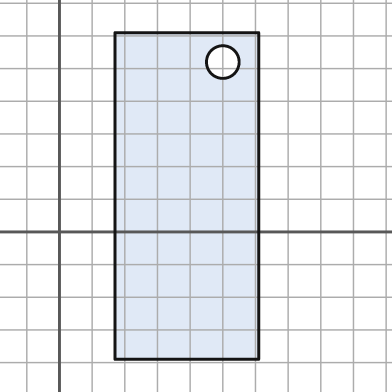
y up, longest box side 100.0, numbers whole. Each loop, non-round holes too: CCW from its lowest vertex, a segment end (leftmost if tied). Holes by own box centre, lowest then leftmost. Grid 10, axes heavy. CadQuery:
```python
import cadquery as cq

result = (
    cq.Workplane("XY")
    .moveTo(17.0, -39.0)
    .lineTo(61.0, -39.0)
    .lineTo(61.0, 61.0)
    .lineTo(17.0, 61.0)
    .close()
    .moveTo(50.0, 52.0)
    .circle(5.0)
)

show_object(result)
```